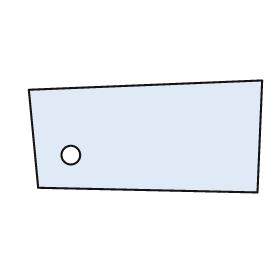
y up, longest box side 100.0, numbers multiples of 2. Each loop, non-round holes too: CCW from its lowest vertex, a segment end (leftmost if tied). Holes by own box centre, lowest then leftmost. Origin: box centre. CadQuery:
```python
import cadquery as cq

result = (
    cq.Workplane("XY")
    .moveTo(48.0, -24.0)
    .lineTo(50.0, 24.0)
    .lineTo(-50.0, 20.0)
    .lineTo(-46.0, -22.0)
    .close()
    .moveTo(-32.0, -8.0)
    .circle(4.0)
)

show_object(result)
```